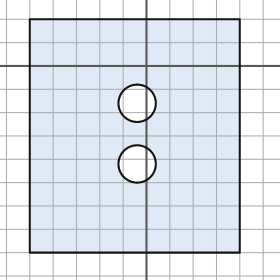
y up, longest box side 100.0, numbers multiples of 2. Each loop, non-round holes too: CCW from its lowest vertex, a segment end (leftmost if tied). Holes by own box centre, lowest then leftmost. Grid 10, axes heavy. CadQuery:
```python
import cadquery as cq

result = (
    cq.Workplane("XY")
    .moveTo(-50.0, -80.0)
    .lineTo(40.0, -80.0)
    .lineTo(40.0, 20.0)
    .lineTo(-50.0, 20.0)
    .close()
    .moveTo(-4.0, -42.0)
    .circle(8.0)
    .moveTo(-4.0, -16.0)
    .circle(8.0)
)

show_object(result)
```